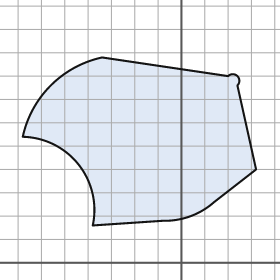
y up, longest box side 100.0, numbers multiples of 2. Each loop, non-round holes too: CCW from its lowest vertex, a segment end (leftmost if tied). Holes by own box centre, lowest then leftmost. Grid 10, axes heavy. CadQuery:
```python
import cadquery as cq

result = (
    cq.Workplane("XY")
    .moveTo(-38.0, 16.0)
    .lineTo(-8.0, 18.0)
    .threePointArc((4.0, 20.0), (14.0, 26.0))
    .lineTo(32.0, 40.0)
    .lineTo(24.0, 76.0)
    .threePointArc((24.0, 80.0), (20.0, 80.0))
    .lineTo(-34.0, 88.0)
    .threePointArc((-56.0, 76.0), (-68.0, 54.0))
    .threePointArc((-44.0, 42.0), (-38.0, 16.0))
    .close()
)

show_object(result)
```